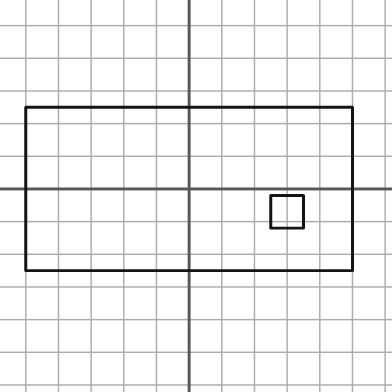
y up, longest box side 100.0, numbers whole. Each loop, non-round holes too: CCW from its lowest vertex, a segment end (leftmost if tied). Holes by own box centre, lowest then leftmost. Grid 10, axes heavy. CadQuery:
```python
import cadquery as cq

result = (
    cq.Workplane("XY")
    .moveTo(-50.0, -25.0)
    .lineTo(50.0, -25.0)
    .lineTo(50.0, 25.0)
    .lineTo(-50.0, 25.0)
    .close()
    .moveTo(25.0, -12.0)
    .lineTo(35.0, -12.0)
    .lineTo(35.0, -2.0)
    .lineTo(25.0, -2.0)
    .close()
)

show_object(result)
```